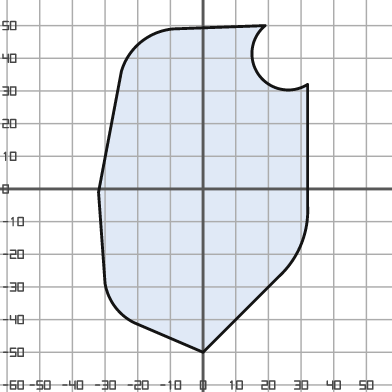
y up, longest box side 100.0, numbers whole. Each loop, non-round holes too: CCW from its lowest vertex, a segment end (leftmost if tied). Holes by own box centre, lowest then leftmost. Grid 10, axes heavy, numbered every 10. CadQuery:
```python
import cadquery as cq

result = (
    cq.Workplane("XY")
    .moveTo(0.0, -50.0)
    .lineTo(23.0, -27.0)
    .threePointArc((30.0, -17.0), (32.0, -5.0))
    .lineTo(32.0, 32.0)
    .threePointArc((17.0, 35.0), (19.0, 50.0))
    .lineTo(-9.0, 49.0)
    .threePointArc((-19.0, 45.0), (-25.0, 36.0))
    .lineTo(-32.0, -1.0)
    .lineTo(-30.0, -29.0)
    .threePointArc((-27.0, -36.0), (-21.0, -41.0))
    .close()
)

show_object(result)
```